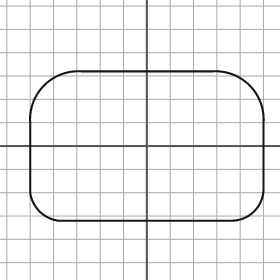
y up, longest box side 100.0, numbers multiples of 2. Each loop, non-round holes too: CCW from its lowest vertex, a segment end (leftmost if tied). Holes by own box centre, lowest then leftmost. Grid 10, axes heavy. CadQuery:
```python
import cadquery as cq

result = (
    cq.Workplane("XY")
    .moveTo(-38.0, -32.0)
    .lineTo(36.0, -32.0)
    .threePointArc((46.0, -28.0), (50.0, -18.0))
    .lineTo(50.0, 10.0)
    .threePointArc((44.0, 26.0), (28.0, 32.0))
    .lineTo(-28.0, 32.0)
    .threePointArc((-44.0, 26.0), (-50.0, 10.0))
    .lineTo(-50.0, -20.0)
    .threePointArc((-46.0, -28.0), (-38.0, -32.0))
    .close()
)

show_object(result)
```